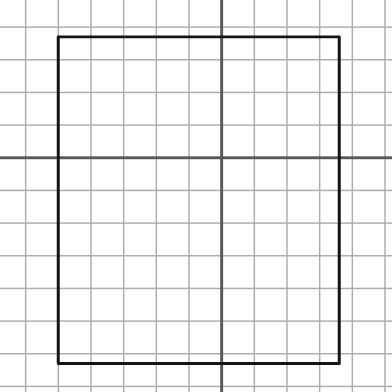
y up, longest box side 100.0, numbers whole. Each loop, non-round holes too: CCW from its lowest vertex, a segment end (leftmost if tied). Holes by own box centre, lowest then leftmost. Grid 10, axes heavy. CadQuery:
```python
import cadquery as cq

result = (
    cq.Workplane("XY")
    .moveTo(-50.0, -63.0)
    .lineTo(36.0, -63.0)
    .lineTo(36.0, 37.0)
    .lineTo(-50.0, 37.0)
    .close()
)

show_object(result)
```